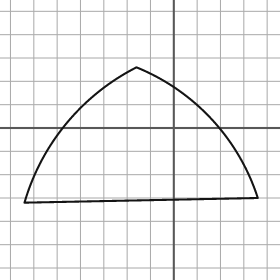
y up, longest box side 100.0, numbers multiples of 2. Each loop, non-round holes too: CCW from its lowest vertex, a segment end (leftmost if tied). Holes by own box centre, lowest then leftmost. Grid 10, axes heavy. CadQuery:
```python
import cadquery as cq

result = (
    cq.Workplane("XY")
    .moveTo(-64.0, -32.0)
    .lineTo(36.0, -30.0)
    .threePointArc((16.0, 4.0), (-16.0, 26.0))
    .threePointArc((-46.0, 2.0), (-64.0, -32.0))
    .close()
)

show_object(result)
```